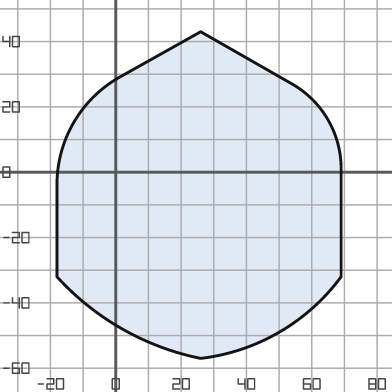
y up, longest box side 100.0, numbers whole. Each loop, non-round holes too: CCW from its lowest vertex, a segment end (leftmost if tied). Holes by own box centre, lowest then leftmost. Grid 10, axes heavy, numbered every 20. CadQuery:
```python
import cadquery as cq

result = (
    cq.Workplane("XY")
    .moveTo(26.0, -57.0)
    .threePointArc((50.0, -49.0), (69.0, -32.0))
    .lineTo(69.0, 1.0)
    .threePointArc((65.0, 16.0), (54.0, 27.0))
    .lineTo(26.0, 43.0)
    .lineTo(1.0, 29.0)
    .threePointArc((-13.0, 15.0), (-18.0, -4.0))
    .lineTo(-18.0, -32.0)
    .threePointArc((2.0, -48.0), (26.0, -57.0))
    .close()
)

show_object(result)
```